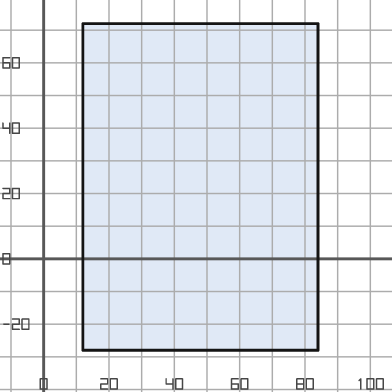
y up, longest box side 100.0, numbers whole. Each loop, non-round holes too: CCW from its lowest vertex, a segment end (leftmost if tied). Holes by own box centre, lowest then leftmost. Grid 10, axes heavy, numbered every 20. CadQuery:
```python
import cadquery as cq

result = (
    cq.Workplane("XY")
    .moveTo(12.0, -28.0)
    .lineTo(84.0, -28.0)
    .lineTo(84.0, 72.0)
    .lineTo(12.0, 72.0)
    .close()
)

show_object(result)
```